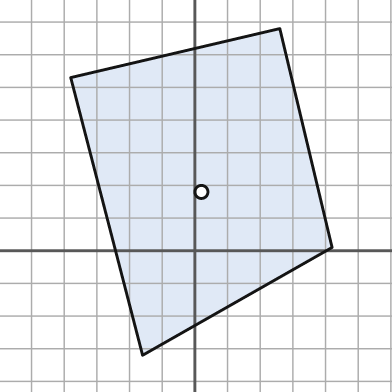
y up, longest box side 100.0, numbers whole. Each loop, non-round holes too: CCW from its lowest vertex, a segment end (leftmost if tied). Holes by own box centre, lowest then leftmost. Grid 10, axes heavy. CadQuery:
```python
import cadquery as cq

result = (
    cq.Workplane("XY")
    .moveTo(-16.0, -32.0)
    .lineTo(42.0, 1.0)
    .lineTo(26.0, 68.0)
    .lineTo(-38.0, 53.0)
    .close()
    .moveTo(2.0, 18.0)
    .circle(2.0)
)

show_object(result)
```